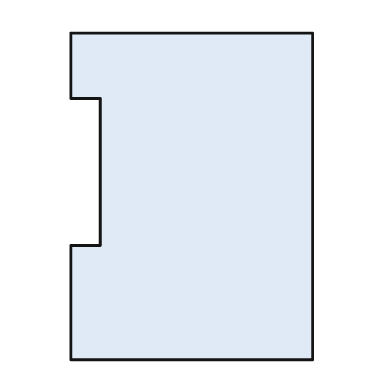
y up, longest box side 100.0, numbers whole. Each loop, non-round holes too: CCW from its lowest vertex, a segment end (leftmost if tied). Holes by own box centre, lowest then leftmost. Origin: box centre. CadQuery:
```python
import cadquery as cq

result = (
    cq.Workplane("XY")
    .moveTo(-37.0, -50.0)
    .lineTo(37.0, -50.0)
    .lineTo(37.0, 50.0)
    .lineTo(-37.0, 50.0)
    .lineTo(-37.0, 30.0)
    .lineTo(-28.0, 30.0)
    .lineTo(-28.0, -15.0)
    .lineTo(-37.0, -15.0)
    .close()
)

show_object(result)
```